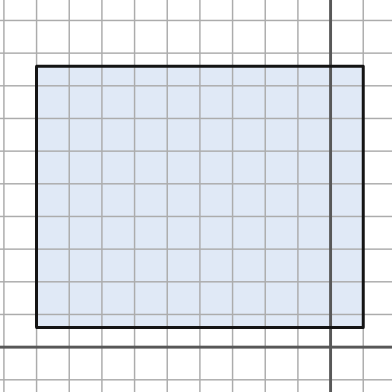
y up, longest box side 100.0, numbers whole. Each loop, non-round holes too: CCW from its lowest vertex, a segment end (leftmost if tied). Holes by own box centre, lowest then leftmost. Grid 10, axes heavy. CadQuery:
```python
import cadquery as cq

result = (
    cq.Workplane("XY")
    .moveTo(-90.0, 6.0)
    .lineTo(10.0, 6.0)
    .lineTo(10.0, 86.0)
    .lineTo(-90.0, 86.0)
    .close()
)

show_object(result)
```